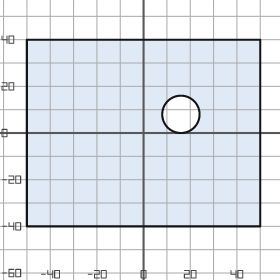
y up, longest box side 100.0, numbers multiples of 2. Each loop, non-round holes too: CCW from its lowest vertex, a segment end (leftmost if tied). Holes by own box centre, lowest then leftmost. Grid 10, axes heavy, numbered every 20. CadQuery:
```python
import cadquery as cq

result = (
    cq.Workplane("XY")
    .moveTo(-50.0, -40.0)
    .lineTo(50.0, -40.0)
    .lineTo(50.0, 40.0)
    .lineTo(-50.0, 40.0)
    .close()
    .moveTo(16.0, 8.0)
    .circle(8.0)
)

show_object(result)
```